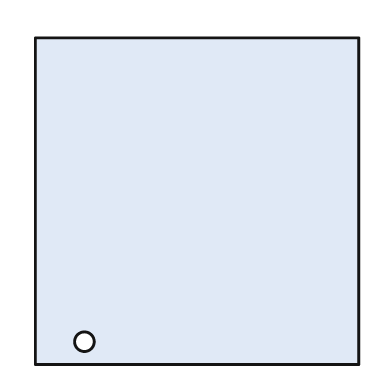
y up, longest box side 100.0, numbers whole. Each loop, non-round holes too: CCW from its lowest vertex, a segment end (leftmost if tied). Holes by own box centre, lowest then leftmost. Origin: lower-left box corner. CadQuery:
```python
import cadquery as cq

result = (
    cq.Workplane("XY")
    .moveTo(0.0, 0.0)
    .lineTo(99.0, 0.0)
    .lineTo(99.0, 100.0)
    .lineTo(0.0, 100.0)
    .close()
    .moveTo(15.0, 7.0)
    .circle(3.0)
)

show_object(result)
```